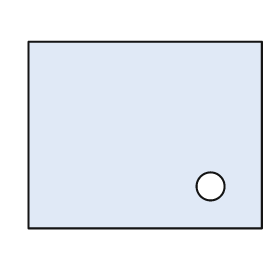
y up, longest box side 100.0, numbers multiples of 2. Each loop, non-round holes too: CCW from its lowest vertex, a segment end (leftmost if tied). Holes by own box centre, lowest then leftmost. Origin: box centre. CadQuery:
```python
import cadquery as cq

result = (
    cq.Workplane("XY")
    .moveTo(-50.0, -40.0)
    .lineTo(50.0, -40.0)
    .lineTo(50.0, 40.0)
    .lineTo(-50.0, 40.0)
    .close()
    .moveTo(28.0, -22.0)
    .circle(6.0)
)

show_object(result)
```